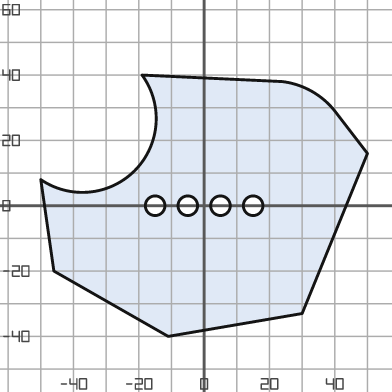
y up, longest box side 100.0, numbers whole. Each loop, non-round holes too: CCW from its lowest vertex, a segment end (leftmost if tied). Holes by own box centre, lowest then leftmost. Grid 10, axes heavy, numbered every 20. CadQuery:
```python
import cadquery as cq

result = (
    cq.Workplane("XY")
    .moveTo(-11.0, -40.0)
    .lineTo(30.0, -33.0)
    .lineTo(50.0, 16.0)
    .lineTo(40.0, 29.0)
    .threePointArc((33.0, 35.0), (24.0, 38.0))
    .lineTo(-19.0, 40.0)
    .threePointArc((-21.0, 11.0), (-50.0, 8.0))
    .lineTo(-46.0, -20.0)
    .close()
    .moveTo(-15.0, 0.0)
    .circle(3.0)
    .moveTo(-5.0, 0.0)
    .circle(3.0)
    .moveTo(5.0, 0.0)
    .circle(3.0)
    .moveTo(15.0, 0.0)
    .circle(3.0)
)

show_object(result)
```